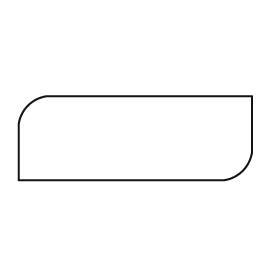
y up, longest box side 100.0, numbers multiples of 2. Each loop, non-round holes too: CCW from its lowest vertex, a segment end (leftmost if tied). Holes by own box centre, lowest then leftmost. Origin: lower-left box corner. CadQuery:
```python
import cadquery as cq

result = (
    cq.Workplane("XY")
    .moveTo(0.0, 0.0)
    .lineTo(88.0, 0.0)
    .threePointArc((96.0, 4.0), (100.0, 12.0))
    .lineTo(100.0, 36.0)
    .lineTo(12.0, 36.0)
    .threePointArc((4.0, 32.0), (0.0, 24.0))
    .close()
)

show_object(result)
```